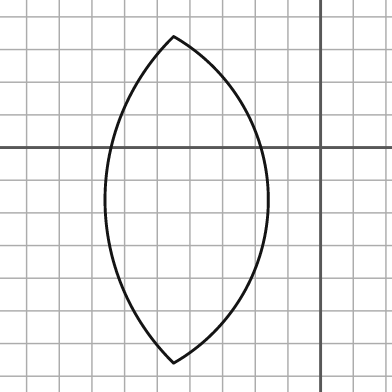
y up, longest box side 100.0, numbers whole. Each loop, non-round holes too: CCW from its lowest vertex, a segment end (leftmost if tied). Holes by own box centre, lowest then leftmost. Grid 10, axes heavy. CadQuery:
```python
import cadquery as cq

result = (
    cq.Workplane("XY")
    .moveTo(-45.0, -66.0)
    .threePointArc((-16.0, -16.0), (-45.0, 34.0))
    .threePointArc((-66.0, -16.0), (-45.0, -66.0))
    .close()
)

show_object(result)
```